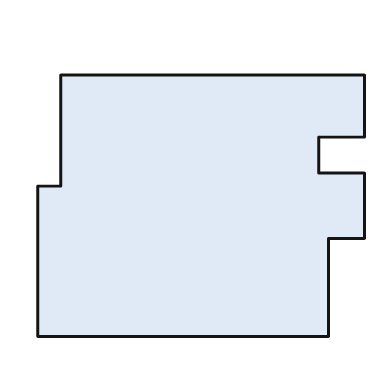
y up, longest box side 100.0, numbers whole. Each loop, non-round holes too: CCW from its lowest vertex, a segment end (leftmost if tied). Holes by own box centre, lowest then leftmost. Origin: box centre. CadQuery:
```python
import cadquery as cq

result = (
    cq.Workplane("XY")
    .moveTo(-50.0, -40.0)
    .lineTo(39.0, -40.0)
    .lineTo(39.0, -10.0)
    .lineTo(50.0, -10.0)
    .lineTo(50.0, 10.0)
    .lineTo(36.0, 10.0)
    .lineTo(36.0, 21.0)
    .lineTo(50.0, 21.0)
    .lineTo(50.0, 40.0)
    .lineTo(-43.0, 40.0)
    .lineTo(-43.0, 6.0)
    .lineTo(-50.0, 6.0)
    .close()
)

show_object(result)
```